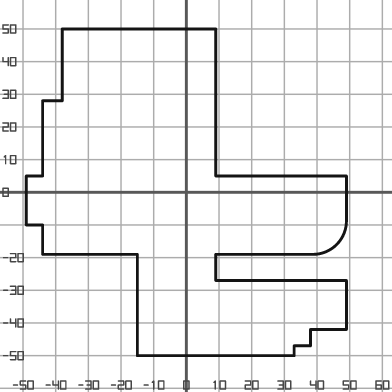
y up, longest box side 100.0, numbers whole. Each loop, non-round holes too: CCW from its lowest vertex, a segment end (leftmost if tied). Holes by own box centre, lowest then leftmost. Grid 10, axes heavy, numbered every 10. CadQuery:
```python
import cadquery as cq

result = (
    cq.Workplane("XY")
    .moveTo(-15.0, -50.0)
    .lineTo(33.0, -50.0)
    .lineTo(33.0, -47.0)
    .lineTo(38.0, -47.0)
    .lineTo(38.0, -42.0)
    .lineTo(49.0, -42.0)
    .lineTo(49.0, -27.0)
    .lineTo(9.0, -27.0)
    .lineTo(9.0, -19.0)
    .lineTo(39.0, -19.0)
    .threePointArc((46.0, -16.0), (49.0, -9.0))
    .lineTo(49.0, 5.0)
    .lineTo(9.0, 5.0)
    .lineTo(9.0, 50.0)
    .lineTo(-38.0, 50.0)
    .lineTo(-38.0, 28.0)
    .lineTo(-44.0, 28.0)
    .lineTo(-44.0, 5.0)
    .lineTo(-49.0, 5.0)
    .lineTo(-49.0, -10.0)
    .lineTo(-44.0, -10.0)
    .lineTo(-44.0, -19.0)
    .lineTo(-15.0, -19.0)
    .close()
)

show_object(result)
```